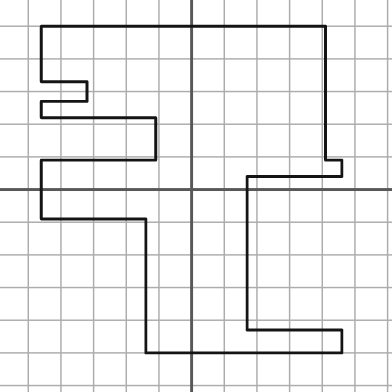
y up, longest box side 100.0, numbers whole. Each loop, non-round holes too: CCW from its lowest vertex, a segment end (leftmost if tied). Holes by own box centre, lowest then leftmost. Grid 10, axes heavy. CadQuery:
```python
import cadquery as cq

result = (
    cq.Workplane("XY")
    .moveTo(-14.0, -50.0)
    .lineTo(46.0, -50.0)
    .lineTo(46.0, -43.0)
    .lineTo(17.0, -43.0)
    .lineTo(17.0, 4.0)
    .lineTo(46.0, 4.0)
    .lineTo(46.0, 9.0)
    .lineTo(41.0, 9.0)
    .lineTo(41.0, 50.0)
    .lineTo(-46.0, 50.0)
    .lineTo(-46.0, 33.0)
    .lineTo(-32.0, 33.0)
    .lineTo(-32.0, 27.0)
    .lineTo(-46.0, 27.0)
    .lineTo(-46.0, 22.0)
    .lineTo(-11.0, 22.0)
    .lineTo(-11.0, 9.0)
    .lineTo(-46.0, 9.0)
    .lineTo(-46.0, -9.0)
    .lineTo(-14.0, -9.0)
    .close()
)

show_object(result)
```